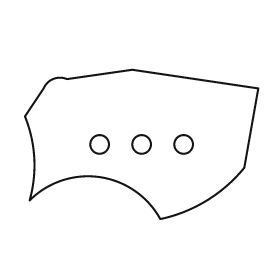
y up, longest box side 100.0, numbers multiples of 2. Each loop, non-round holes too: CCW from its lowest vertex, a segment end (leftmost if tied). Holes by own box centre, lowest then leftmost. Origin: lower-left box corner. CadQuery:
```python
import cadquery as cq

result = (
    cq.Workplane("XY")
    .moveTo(58.0, 0.0)
    .threePointArc((78.0, 8.0), (94.0, 22.0))
    .lineTo(100.0, 56.0)
    .lineTo(46.0, 64.0)
    .lineTo(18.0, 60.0)
    .threePointArc((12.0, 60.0), (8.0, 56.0))
    .lineTo(0.0, 44.0)
    .threePointArc((4.0, 26.0), (2.0, 8.0))
    .threePointArc((32.0, 18.0), (58.0, 0.0))
    .close()
    .moveTo(32.0, 32.0)
    .circle(4.0)
    .moveTo(50.0, 32.0)
    .circle(4.0)
    .moveTo(68.0, 32.0)
    .circle(4.0)
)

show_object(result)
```